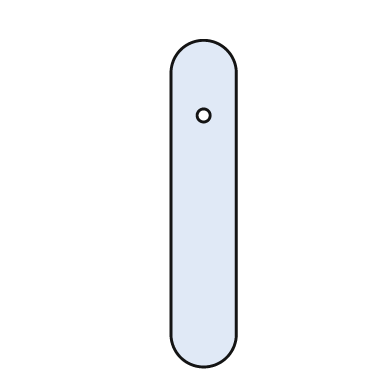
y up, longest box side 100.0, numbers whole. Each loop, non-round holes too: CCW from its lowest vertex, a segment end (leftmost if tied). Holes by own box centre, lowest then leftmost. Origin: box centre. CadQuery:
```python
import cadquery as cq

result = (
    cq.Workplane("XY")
    .moveTo(-10.0, -40.0)
    .threePointArc((0.0, -50.0), (10.0, -40.0))
    .lineTo(10.0, 40.0)
    .threePointArc((0.0, 50.0), (-10.0, 40.0))
    .close()
    .moveTo(0.0, 27.0)
    .circle(2.0)
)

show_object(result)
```